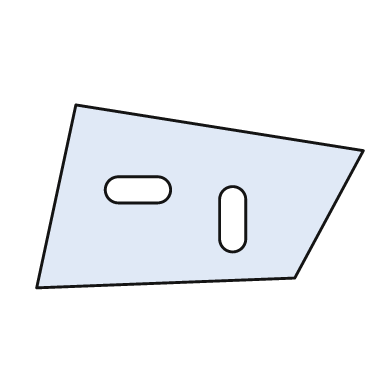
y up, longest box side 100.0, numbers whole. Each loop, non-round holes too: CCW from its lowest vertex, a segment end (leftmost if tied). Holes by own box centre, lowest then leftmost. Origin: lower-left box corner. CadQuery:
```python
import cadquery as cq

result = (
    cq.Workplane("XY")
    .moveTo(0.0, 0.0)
    .lineTo(79.0, 3.0)
    .lineTo(100.0, 42.0)
    .lineTo(12.0, 56.0)
    .close()
    .moveTo(56.0, 15.0)
    .threePointArc((60.0, 11.0), (64.0, 15.0))
    .lineTo(64.0, 27.0)
    .threePointArc((60.0, 31.0), (56.0, 27.0))
    .close()
    .moveTo(25.0, 26.0)
    .lineTo(37.0, 26.0)
    .threePointArc((41.0, 30.0), (37.0, 34.0))
    .lineTo(25.0, 34.0)
    .threePointArc((21.0, 30.0), (25.0, 26.0))
    .close()
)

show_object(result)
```